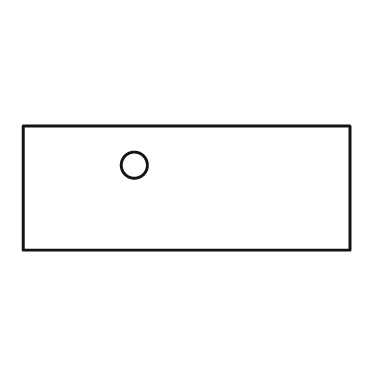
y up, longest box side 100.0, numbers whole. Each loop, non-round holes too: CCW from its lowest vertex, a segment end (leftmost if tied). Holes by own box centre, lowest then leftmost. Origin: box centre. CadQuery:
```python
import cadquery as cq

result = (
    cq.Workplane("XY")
    .moveTo(-50.0, -19.0)
    .lineTo(50.0, -19.0)
    .lineTo(50.0, 19.0)
    .lineTo(-50.0, 19.0)
    .close()
    .moveTo(-16.0, 7.0)
    .circle(4.0)
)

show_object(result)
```